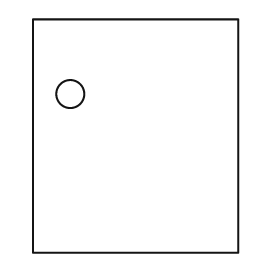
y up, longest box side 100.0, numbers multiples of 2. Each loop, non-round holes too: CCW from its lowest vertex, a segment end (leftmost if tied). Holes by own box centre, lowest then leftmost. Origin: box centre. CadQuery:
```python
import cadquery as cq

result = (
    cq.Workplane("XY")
    .moveTo(-44.0, -50.0)
    .lineTo(44.0, -50.0)
    .lineTo(44.0, 50.0)
    .lineTo(-44.0, 50.0)
    .close()
    .moveTo(-28.0, 18.0)
    .circle(6.0)
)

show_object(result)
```